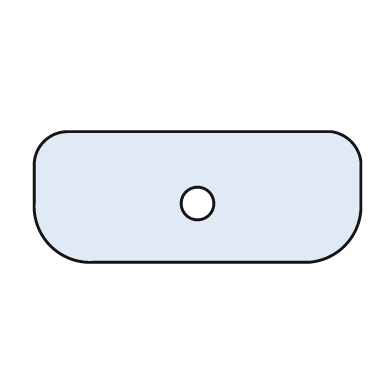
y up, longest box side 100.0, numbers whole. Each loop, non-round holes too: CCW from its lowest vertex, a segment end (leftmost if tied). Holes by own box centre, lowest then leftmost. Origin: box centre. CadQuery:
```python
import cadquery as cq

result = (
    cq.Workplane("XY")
    .moveTo(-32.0, -20.0)
    .lineTo(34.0, -20.0)
    .threePointArc((45.0, -15.0), (50.0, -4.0))
    .lineTo(50.0, 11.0)
    .threePointArc((47.0, 17.0), (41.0, 20.0))
    .lineTo(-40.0, 20.0)
    .threePointArc((-47.0, 17.0), (-50.0, 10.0))
    .lineTo(-50.0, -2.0)
    .threePointArc((-45.0, -15.0), (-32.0, -20.0))
    .close()
    .moveTo(0.0, -2.0)
    .circle(5.0)
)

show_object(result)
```